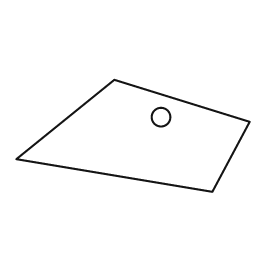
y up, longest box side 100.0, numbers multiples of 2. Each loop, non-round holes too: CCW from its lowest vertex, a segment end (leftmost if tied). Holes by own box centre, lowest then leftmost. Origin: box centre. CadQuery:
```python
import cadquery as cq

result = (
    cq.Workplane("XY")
    .moveTo(34.0, -24.0)
    .lineTo(50.0, 6.0)
    .lineTo(-8.0, 24.0)
    .lineTo(-50.0, -10.0)
    .close()
    .moveTo(12.0, 8.0)
    .circle(4.0)
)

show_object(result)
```